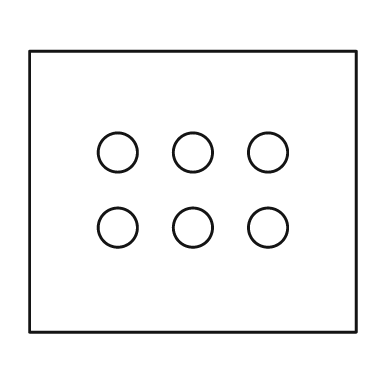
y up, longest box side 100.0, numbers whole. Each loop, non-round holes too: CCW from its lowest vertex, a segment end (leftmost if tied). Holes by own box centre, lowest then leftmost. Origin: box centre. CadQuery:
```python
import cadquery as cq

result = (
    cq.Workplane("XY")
    .moveTo(-50.0, -43.0)
    .lineTo(50.0, -43.0)
    .lineTo(50.0, 43.0)
    .lineTo(-50.0, 43.0)
    .close()
    .moveTo(-23.0, -11.0)
    .circle(6.0)
    .moveTo(0.0, -11.0)
    .circle(6.0)
    .moveTo(23.0, -11.0)
    .circle(6.0)
    .moveTo(-23.0, 12.0)
    .circle(6.0)
    .moveTo(0.0, 12.0)
    .circle(6.0)
    .moveTo(23.0, 12.0)
    .circle(6.0)
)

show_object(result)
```